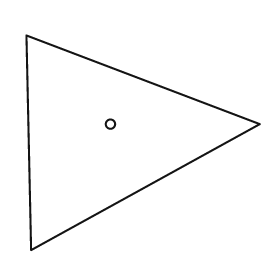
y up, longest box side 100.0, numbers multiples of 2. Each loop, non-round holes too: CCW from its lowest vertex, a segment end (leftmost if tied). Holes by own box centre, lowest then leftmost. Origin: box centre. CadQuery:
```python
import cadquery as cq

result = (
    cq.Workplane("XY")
    .moveTo(-48.0, -46.0)
    .lineTo(50.0, 8.0)
    .lineTo(-50.0, 46.0)
    .close()
    .moveTo(-14.0, 8.0)
    .circle(2.0)
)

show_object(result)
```